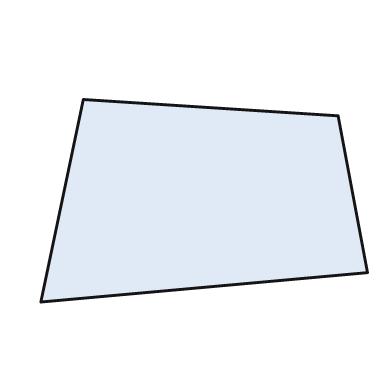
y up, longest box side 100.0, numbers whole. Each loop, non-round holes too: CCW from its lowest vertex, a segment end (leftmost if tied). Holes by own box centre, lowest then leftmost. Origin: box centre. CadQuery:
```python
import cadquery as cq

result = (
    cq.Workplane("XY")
    .moveTo(-50.0, -31.0)
    .lineTo(50.0, -22.0)
    .lineTo(41.0, 26.0)
    .lineTo(-37.0, 31.0)
    .close()
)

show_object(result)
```